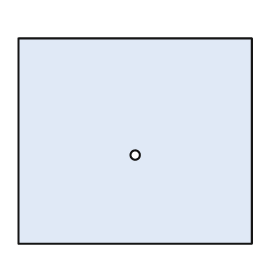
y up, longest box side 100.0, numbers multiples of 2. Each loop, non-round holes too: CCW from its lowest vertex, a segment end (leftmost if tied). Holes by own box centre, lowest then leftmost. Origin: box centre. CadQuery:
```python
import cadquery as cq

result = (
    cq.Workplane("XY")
    .moveTo(-50.0, -44.0)
    .lineTo(50.0, -44.0)
    .lineTo(50.0, 44.0)
    .lineTo(-50.0, 44.0)
    .close()
    .moveTo(0.0, -6.0)
    .circle(2.0)
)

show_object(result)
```